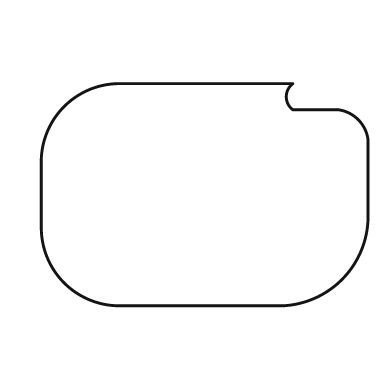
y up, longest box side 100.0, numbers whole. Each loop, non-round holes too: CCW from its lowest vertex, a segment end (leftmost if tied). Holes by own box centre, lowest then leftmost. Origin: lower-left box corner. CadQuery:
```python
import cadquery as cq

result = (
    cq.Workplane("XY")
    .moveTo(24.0, 0.0)
    .lineTo(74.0, 0.0)
    .threePointArc((92.0, 8.0), (100.0, 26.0))
    .lineTo(100.0, 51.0)
    .threePointArc((97.0, 57.0), (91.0, 60.0))
    .lineTo(77.0, 60.0)
    .threePointArc((75.0, 64.0), (77.0, 68.0))
    .lineTo(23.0, 68.0)
    .threePointArc((7.0, 61.0), (0.0, 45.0))
    .lineTo(0.0, 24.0)
    .threePointArc((7.0, 7.0), (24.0, 0.0))
    .close()
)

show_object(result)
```